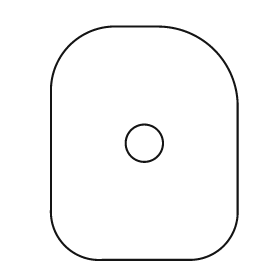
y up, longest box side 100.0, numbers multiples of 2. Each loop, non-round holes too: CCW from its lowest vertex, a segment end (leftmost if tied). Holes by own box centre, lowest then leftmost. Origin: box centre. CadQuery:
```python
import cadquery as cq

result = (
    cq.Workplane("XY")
    .moveTo(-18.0, -50.0)
    .lineTo(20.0, -50.0)
    .threePointArc((34.0, -44.0), (40.0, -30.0))
    .lineTo(40.0, 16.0)
    .threePointArc((30.0, 40.0), (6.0, 50.0))
    .lineTo(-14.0, 50.0)
    .threePointArc((-32.0, 42.0), (-40.0, 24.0))
    .lineTo(-40.0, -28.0)
    .threePointArc((-34.0, -44.0), (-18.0, -50.0))
    .close()
    .moveTo(0.0, 0.0)
    .circle(8.0)
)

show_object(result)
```